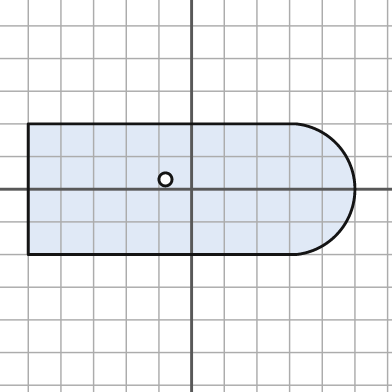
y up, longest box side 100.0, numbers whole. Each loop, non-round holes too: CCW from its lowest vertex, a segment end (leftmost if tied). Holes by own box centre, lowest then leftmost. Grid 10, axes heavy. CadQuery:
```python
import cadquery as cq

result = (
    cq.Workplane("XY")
    .moveTo(-50.0, -20.0)
    .lineTo(32.0, -20.0)
    .threePointArc((50.0, 0.0), (32.0, 20.0))
    .lineTo(-50.0, 20.0)
    .close()
    .moveTo(-8.0, 3.0)
    .circle(2.0)
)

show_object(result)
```